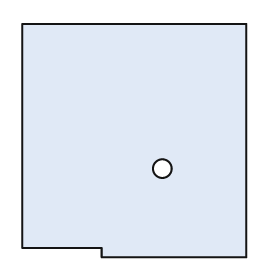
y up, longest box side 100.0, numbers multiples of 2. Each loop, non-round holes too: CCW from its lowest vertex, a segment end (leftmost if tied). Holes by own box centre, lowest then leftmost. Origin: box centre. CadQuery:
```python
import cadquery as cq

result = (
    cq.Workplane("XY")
    .moveTo(-14.0, -50.0)
    .lineTo(48.0, -50.0)
    .lineTo(48.0, 50.0)
    .lineTo(-48.0, 50.0)
    .lineTo(-48.0, -46.0)
    .lineTo(-14.0, -46.0)
    .close()
    .moveTo(12.0, -12.0)
    .circle(4.0)
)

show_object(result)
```